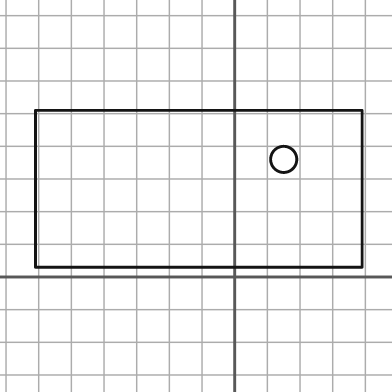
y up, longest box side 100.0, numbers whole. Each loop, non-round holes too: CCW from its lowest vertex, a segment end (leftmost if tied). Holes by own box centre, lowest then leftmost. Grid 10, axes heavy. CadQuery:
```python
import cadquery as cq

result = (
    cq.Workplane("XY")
    .moveTo(-61.0, 3.0)
    .lineTo(39.0, 3.0)
    .lineTo(39.0, 51.0)
    .lineTo(-61.0, 51.0)
    .close()
    .moveTo(15.0, 36.0)
    .circle(4.0)
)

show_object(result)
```